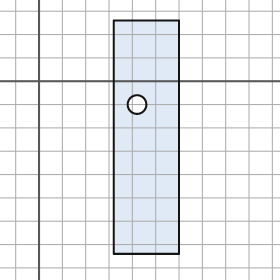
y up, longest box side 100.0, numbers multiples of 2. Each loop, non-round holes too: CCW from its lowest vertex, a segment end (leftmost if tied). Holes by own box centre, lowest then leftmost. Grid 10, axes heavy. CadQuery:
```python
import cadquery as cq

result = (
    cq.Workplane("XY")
    .moveTo(32.0, -74.0)
    .lineTo(60.0, -74.0)
    .lineTo(60.0, 26.0)
    .lineTo(32.0, 26.0)
    .close()
    .moveTo(42.0, -10.0)
    .circle(4.0)
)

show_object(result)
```